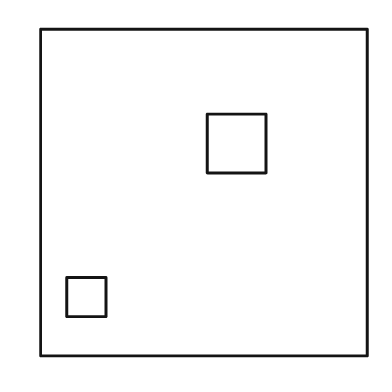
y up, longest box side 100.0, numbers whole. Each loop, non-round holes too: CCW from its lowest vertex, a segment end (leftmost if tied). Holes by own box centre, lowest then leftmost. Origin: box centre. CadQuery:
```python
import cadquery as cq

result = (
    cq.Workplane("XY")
    .moveTo(-50.0, -50.0)
    .lineTo(50.0, -50.0)
    .lineTo(50.0, 50.0)
    .lineTo(-50.0, 50.0)
    .close()
    .moveTo(-42.0, -38.0)
    .lineTo(-30.0, -38.0)
    .lineTo(-30.0, -26.0)
    .lineTo(-42.0, -26.0)
    .close()
    .moveTo(1.0, 6.0)
    .lineTo(19.0, 6.0)
    .lineTo(19.0, 24.0)
    .lineTo(1.0, 24.0)
    .close()
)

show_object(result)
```